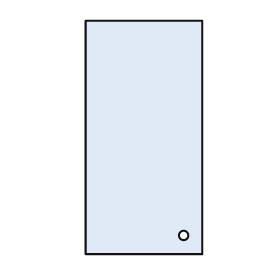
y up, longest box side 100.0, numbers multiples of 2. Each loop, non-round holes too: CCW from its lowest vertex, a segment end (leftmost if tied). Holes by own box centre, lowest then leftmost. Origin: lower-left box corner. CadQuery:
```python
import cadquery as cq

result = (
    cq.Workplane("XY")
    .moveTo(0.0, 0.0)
    .lineTo(50.0, 0.0)
    .lineTo(50.0, 100.0)
    .lineTo(0.0, 100.0)
    .close()
    .moveTo(42.0, 8.0)
    .circle(2.0)
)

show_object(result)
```